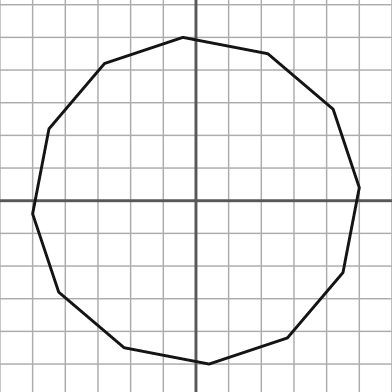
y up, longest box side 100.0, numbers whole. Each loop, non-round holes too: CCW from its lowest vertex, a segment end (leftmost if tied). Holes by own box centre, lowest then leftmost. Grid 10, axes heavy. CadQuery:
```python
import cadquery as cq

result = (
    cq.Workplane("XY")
    .moveTo(4.0, -50.0)
    .lineTo(28.0, -42.0)
    .lineTo(45.0, -22.0)
    .lineTo(50.0, 4.0)
    .lineTo(42.0, 28.0)
    .lineTo(22.0, 45.0)
    .lineTo(-4.0, 50.0)
    .lineTo(-28.0, 42.0)
    .lineTo(-45.0, 22.0)
    .lineTo(-50.0, -4.0)
    .lineTo(-42.0, -28.0)
    .lineTo(-22.0, -45.0)
    .close()
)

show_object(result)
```